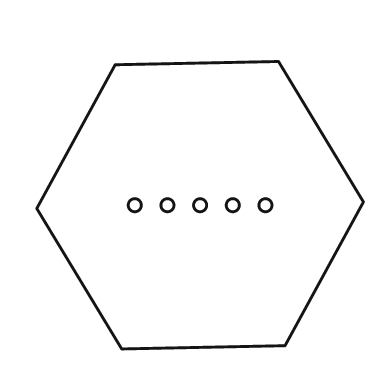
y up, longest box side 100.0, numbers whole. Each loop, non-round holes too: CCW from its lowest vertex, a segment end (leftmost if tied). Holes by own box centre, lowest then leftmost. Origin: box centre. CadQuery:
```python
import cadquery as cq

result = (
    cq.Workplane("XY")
    .moveTo(-24.0, -44.0)
    .lineTo(26.0, -43.0)
    .lineTo(50.0, 1.0)
    .lineTo(24.0, 44.0)
    .lineTo(-26.0, 43.0)
    .lineTo(-50.0, -1.0)
    .close()
    .moveTo(-20.0, 0.0)
    .circle(2.0)
    .moveTo(-10.0, 0.0)
    .circle(2.0)
    .moveTo(0.0, 0.0)
    .circle(2.0)
    .moveTo(10.0, 0.0)
    .circle(2.0)
    .moveTo(20.0, 0.0)
    .circle(2.0)
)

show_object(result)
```